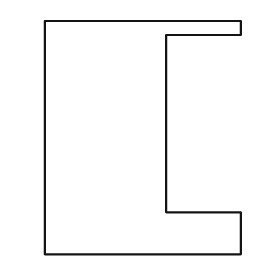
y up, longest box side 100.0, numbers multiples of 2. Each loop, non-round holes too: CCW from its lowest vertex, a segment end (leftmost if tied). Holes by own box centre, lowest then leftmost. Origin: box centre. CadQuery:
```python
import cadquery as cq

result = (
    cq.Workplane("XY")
    .moveTo(-42.0, -50.0)
    .lineTo(42.0, -50.0)
    .lineTo(42.0, -32.0)
    .lineTo(10.0, -32.0)
    .lineTo(10.0, 44.0)
    .lineTo(42.0, 44.0)
    .lineTo(42.0, 50.0)
    .lineTo(-42.0, 50.0)
    .close()
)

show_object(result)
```